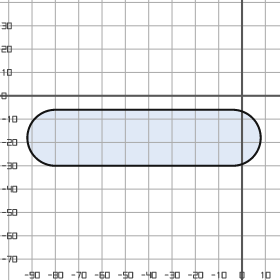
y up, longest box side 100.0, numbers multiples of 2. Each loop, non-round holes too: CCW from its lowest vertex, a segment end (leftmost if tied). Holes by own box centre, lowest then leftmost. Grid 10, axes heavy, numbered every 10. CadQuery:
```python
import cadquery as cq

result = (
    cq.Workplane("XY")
    .moveTo(-80.0, -30.0)
    .lineTo(-4.0, -30.0)
    .threePointArc((8.0, -18.0), (-4.0, -6.0))
    .lineTo(-80.0, -6.0)
    .threePointArc((-92.0, -18.0), (-80.0, -30.0))
    .close()
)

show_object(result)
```